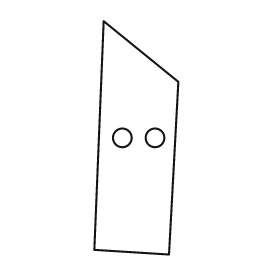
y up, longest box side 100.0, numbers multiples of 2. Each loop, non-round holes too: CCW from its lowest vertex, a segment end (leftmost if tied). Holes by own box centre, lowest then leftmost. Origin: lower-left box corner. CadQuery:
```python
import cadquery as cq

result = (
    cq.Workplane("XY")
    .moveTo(32.0, 0.0)
    .lineTo(36.0, 74.0)
    .lineTo(4.0, 100.0)
    .lineTo(0.0, 2.0)
    .close()
    .moveTo(12.0, 50.0)
    .circle(4.0)
    .moveTo(26.0, 50.0)
    .circle(4.0)
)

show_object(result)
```